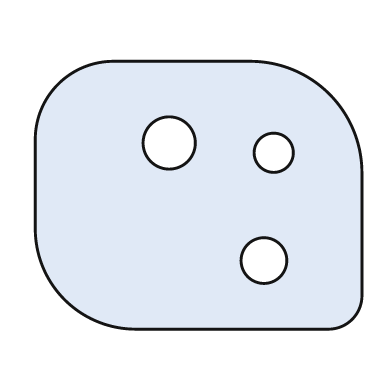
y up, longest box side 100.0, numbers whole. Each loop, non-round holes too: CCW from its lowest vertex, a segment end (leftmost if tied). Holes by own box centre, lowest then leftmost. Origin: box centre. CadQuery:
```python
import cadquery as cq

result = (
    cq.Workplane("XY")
    .moveTo(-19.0, -41.0)
    .lineTo(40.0, -41.0)
    .threePointArc((47.0, -38.0), (50.0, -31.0))
    .lineTo(50.0, 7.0)
    .threePointArc((40.0, 31.0), (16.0, 41.0))
    .lineTo(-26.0, 41.0)
    .threePointArc((-43.0, 34.0), (-50.0, 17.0))
    .lineTo(-50.0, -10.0)
    .threePointArc((-41.0, -32.0), (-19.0, -41.0))
    .close()
    .moveTo(20.0, -20.0)
    .circle(7.0)
    .moveTo(23.0, 13.0)
    .circle(6.0)
    .moveTo(-9.0, 16.0)
    .circle(8.0)
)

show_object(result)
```